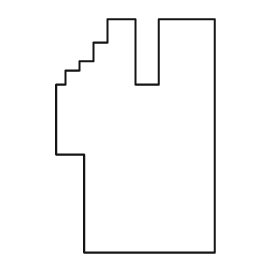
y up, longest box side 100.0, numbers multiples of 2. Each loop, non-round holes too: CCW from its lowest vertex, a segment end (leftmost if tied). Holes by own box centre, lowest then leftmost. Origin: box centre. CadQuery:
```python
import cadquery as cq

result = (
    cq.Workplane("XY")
    .moveTo(-22.0, -50.0)
    .lineTo(34.0, -50.0)
    .lineTo(34.0, 50.0)
    .lineTo(10.0, 50.0)
    .lineTo(10.0, 22.0)
    .lineTo(0.0, 22.0)
    .lineTo(0.0, 50.0)
    .lineTo(-12.0, 50.0)
    .lineTo(-12.0, 40.0)
    .lineTo(-18.0, 40.0)
    .lineTo(-18.0, 32.0)
    .lineTo(-24.0, 32.0)
    .lineTo(-24.0, 28.0)
    .lineTo(-30.0, 28.0)
    .lineTo(-30.0, 22.0)
    .lineTo(-34.0, 22.0)
    .lineTo(-34.0, -8.0)
    .lineTo(-22.0, -8.0)
    .close()
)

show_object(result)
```